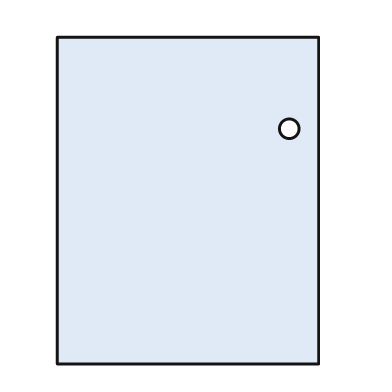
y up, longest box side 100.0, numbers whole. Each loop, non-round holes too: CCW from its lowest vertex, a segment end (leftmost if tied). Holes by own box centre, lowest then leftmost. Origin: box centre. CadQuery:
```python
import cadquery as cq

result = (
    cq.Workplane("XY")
    .moveTo(-40.0, -50.0)
    .lineTo(40.0, -50.0)
    .lineTo(40.0, 50.0)
    .lineTo(-40.0, 50.0)
    .close()
    .moveTo(31.0, 22.0)
    .circle(3.0)
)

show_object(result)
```